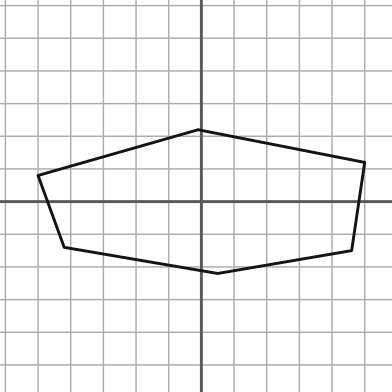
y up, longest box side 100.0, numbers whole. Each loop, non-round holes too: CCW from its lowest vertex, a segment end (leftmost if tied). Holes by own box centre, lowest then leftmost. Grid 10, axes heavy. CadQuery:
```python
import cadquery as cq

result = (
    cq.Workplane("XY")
    .moveTo(5.0, -22.0)
    .lineTo(46.0, -15.0)
    .lineTo(50.0, 12.0)
    .lineTo(-1.0, 22.0)
    .lineTo(-50.0, 8.0)
    .lineTo(-42.0, -14.0)
    .close()
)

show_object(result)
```